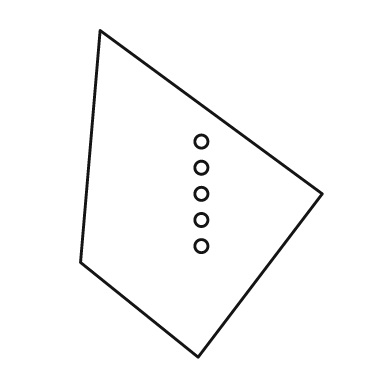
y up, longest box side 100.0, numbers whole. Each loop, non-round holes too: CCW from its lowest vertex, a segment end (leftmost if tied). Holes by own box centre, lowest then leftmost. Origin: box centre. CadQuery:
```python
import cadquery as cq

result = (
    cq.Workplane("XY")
    .moveTo(-1.0, -50.0)
    .lineTo(37.0, 0.0)
    .lineTo(-31.0, 50.0)
    .lineTo(-37.0, -21.0)
    .close()
    .moveTo(0.0, -16.0)
    .circle(2.0)
    .moveTo(0.0, -8.0)
    .circle(2.0)
    .moveTo(0.0, 0.0)
    .circle(2.0)
    .moveTo(0.0, 8.0)
    .circle(2.0)
    .moveTo(0.0, 16.0)
    .circle(2.0)
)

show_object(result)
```